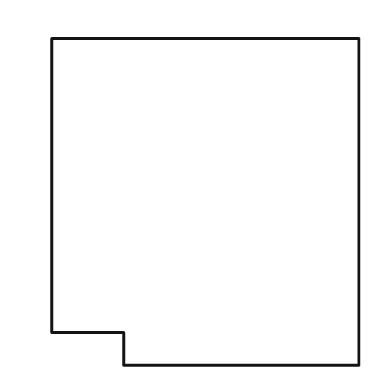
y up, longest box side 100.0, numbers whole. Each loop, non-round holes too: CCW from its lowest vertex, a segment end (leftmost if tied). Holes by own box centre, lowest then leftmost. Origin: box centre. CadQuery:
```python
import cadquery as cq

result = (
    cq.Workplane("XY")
    .moveTo(-25.0, -50.0)
    .lineTo(47.0, -50.0)
    .lineTo(47.0, 50.0)
    .lineTo(-47.0, 50.0)
    .lineTo(-47.0, -40.0)
    .lineTo(-25.0, -40.0)
    .close()
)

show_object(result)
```